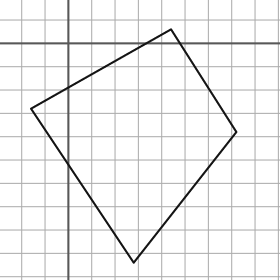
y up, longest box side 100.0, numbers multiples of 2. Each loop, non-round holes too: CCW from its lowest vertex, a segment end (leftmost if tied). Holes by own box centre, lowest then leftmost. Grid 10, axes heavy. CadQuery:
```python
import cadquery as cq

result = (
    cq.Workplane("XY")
    .moveTo(28.0, -94.0)
    .lineTo(72.0, -38.0)
    .lineTo(44.0, 6.0)
    .lineTo(-16.0, -28.0)
    .close()
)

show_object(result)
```